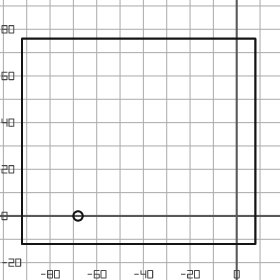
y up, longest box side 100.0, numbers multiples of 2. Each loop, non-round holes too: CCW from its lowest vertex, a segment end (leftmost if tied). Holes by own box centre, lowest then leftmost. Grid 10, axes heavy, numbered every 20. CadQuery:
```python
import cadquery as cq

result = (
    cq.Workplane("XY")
    .moveTo(-92.0, -12.0)
    .lineTo(8.0, -12.0)
    .lineTo(8.0, 76.0)
    .lineTo(-92.0, 76.0)
    .close()
    .moveTo(-68.0, 0.0)
    .circle(2.0)
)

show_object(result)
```